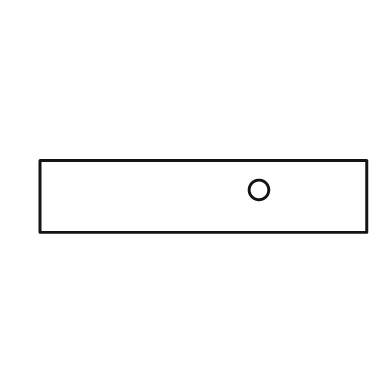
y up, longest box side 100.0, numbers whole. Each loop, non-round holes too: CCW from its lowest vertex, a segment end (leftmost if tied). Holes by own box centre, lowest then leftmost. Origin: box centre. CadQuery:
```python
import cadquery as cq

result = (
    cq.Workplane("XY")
    .moveTo(-50.0, -11.0)
    .lineTo(50.0, -11.0)
    .lineTo(50.0, 11.0)
    .lineTo(-50.0, 11.0)
    .close()
    .moveTo(17.0, 2.0)
    .circle(3.0)
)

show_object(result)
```